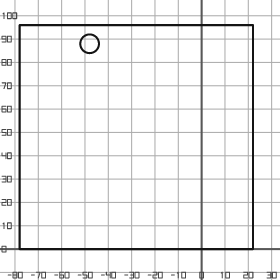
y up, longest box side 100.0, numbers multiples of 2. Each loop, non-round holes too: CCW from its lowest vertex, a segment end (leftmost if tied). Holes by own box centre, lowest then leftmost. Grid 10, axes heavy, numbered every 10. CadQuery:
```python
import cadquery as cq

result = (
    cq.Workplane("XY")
    .moveTo(-78.0, 0.0)
    .lineTo(22.0, 0.0)
    .lineTo(22.0, 96.0)
    .lineTo(-78.0, 96.0)
    .close()
    .moveTo(-48.0, 88.0)
    .circle(4.0)
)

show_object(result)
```